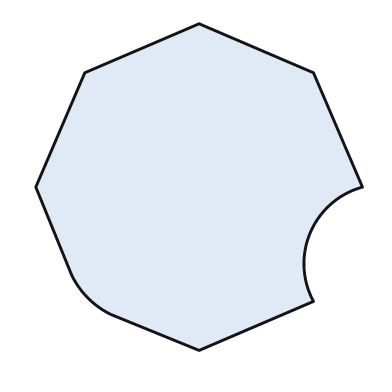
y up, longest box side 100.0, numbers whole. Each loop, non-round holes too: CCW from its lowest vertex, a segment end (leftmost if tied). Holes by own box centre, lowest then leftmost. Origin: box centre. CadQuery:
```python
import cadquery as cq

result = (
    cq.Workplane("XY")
    .moveTo(0.0, -50.0)
    .lineTo(35.0, -35.0)
    .threePointArc((34.0, -14.0), (50.0, 0.0))
    .lineTo(35.0, 35.0)
    .lineTo(0.0, 50.0)
    .lineTo(-35.0, 35.0)
    .lineTo(-50.0, 0.0)
    .lineTo(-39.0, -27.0)
    .threePointArc((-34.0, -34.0), (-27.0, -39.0))
    .close()
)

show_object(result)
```